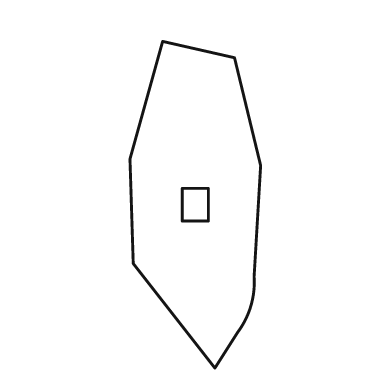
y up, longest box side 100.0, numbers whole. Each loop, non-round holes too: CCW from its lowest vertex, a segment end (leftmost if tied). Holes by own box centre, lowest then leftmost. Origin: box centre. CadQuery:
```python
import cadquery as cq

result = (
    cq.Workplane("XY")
    .moveTo(6.0, -50.0)
    .lineTo(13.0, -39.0)
    .threePointArc((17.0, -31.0), (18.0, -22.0))
    .lineTo(20.0, 12.0)
    .lineTo(12.0, 45.0)
    .lineTo(-10.0, 50.0)
    .lineTo(-20.0, 14.0)
    .lineTo(-19.0, -18.0)
    .close()
    .moveTo(-4.0, -5.0)
    .lineTo(4.0, -5.0)
    .lineTo(4.0, 5.0)
    .lineTo(-4.0, 5.0)
    .close()
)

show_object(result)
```